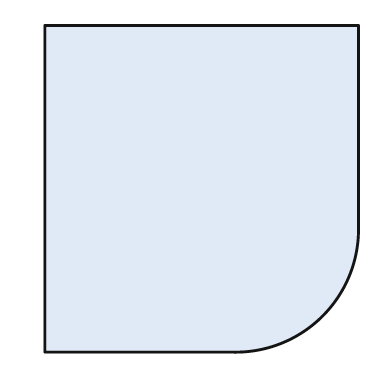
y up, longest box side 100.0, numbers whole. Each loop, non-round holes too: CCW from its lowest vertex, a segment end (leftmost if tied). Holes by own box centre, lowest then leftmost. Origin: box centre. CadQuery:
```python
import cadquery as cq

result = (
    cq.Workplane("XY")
    .moveTo(-48.0, -50.0)
    .lineTo(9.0, -50.0)
    .threePointArc((37.0, -39.0), (48.0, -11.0))
    .lineTo(48.0, 50.0)
    .lineTo(-48.0, 50.0)
    .close()
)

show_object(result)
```